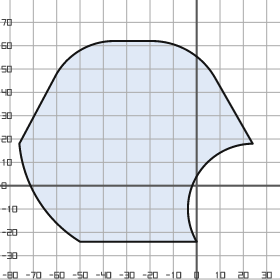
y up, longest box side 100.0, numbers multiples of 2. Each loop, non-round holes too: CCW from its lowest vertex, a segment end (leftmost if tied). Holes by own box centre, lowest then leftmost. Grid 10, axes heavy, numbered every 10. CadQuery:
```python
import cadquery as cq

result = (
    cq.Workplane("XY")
    .moveTo(-50.0, -24.0)
    .lineTo(0.0, -24.0)
    .threePointArc((0.0, 4.0), (24.0, 18.0))
    .lineTo(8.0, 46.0)
    .threePointArc((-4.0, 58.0), (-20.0, 62.0))
    .lineTo(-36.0, 62.0)
    .threePointArc((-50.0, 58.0), (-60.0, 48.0))
    .lineTo(-76.0, 18.0)
    .threePointArc((-68.0, -6.0), (-50.0, -24.0))
    .close()
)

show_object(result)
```